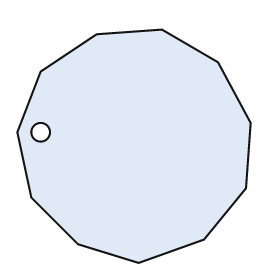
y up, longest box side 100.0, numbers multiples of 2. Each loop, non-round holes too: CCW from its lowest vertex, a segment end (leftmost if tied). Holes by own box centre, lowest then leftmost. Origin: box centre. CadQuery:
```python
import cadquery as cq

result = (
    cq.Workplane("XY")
    .moveTo(2.0, -50.0)
    .lineTo(30.0, -40.0)
    .lineTo(48.0, -18.0)
    .lineTo(50.0, 10.0)
    .lineTo(36.0, 36.0)
    .lineTo(12.0, 50.0)
    .lineTo(-16.0, 48.0)
    .lineTo(-40.0, 32.0)
    .lineTo(-50.0, 6.0)
    .lineTo(-44.0, -22.0)
    .lineTo(-24.0, -42.0)
    .close()
    .moveTo(-40.0, 6.0)
    .circle(4.0)
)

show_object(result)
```